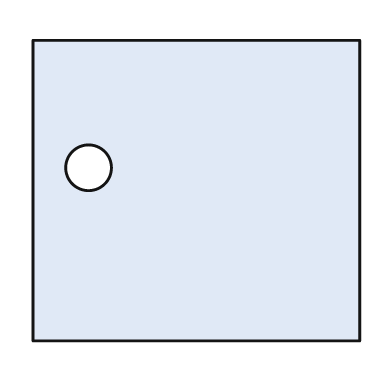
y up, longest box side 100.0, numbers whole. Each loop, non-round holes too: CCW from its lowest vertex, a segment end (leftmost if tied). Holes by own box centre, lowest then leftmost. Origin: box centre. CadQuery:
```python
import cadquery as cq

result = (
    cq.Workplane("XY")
    .moveTo(-50.0, -46.0)
    .lineTo(50.0, -46.0)
    .lineTo(50.0, 46.0)
    .lineTo(-50.0, 46.0)
    .close()
    .moveTo(-33.0, 7.0)
    .circle(7.0)
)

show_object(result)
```